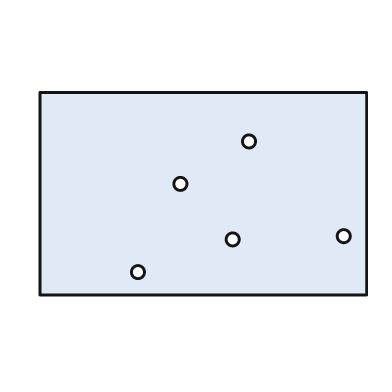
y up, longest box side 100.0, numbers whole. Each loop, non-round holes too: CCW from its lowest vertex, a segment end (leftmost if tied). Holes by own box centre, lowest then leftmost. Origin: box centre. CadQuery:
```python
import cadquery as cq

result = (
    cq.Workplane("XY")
    .moveTo(-50.0, -31.0)
    .lineTo(50.0, -31.0)
    .lineTo(50.0, 31.0)
    .lineTo(-50.0, 31.0)
    .close()
    .moveTo(-20.0, -24.0)
    .circle(2.0)
    .moveTo(9.0, -14.0)
    .circle(2.0)
    .moveTo(43.0, -13.0)
    .circle(2.0)
    .moveTo(-7.0, 3.0)
    .circle(2.0)
    .moveTo(14.0, 16.0)
    .circle(2.0)
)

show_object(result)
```